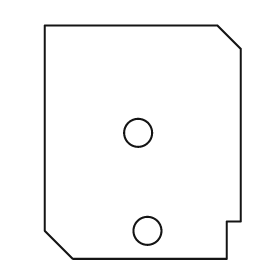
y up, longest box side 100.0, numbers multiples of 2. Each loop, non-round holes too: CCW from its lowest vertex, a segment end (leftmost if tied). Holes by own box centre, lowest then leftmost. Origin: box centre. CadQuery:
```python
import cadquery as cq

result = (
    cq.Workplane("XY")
    .moveTo(-30.0, -50.0)
    .lineTo(36.0, -50.0)
    .lineTo(36.0, -34.0)
    .lineTo(42.0, -34.0)
    .lineTo(42.0, 40.0)
    .lineTo(32.0, 50.0)
    .lineTo(-42.0, 50.0)
    .lineTo(-42.0, -38.0)
    .close()
    .moveTo(2.0, -38.0)
    .circle(6.0)
    .moveTo(-2.0, 4.0)
    .circle(6.0)
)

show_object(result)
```